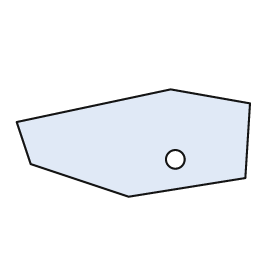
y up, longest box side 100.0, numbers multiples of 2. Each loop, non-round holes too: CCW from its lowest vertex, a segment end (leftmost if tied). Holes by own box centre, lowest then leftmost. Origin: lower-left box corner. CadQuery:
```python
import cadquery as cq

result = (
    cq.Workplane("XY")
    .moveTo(48.0, 0.0)
    .lineTo(98.0, 8.0)
    .lineTo(100.0, 40.0)
    .lineTo(66.0, 46.0)
    .lineTo(0.0, 32.0)
    .lineTo(6.0, 14.0)
    .close()
    .moveTo(68.0, 16.0)
    .circle(4.0)
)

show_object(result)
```